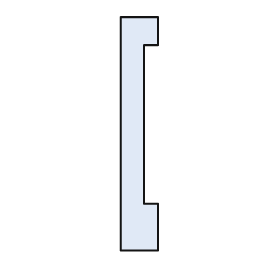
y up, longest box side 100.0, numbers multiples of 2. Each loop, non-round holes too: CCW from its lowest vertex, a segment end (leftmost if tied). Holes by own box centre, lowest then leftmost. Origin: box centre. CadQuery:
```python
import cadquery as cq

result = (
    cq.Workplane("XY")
    .moveTo(-8.0, -50.0)
    .lineTo(8.0, -50.0)
    .lineTo(8.0, -30.0)
    .lineTo(2.0, -30.0)
    .lineTo(2.0, 38.0)
    .lineTo(8.0, 38.0)
    .lineTo(8.0, 50.0)
    .lineTo(-8.0, 50.0)
    .close()
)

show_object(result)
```